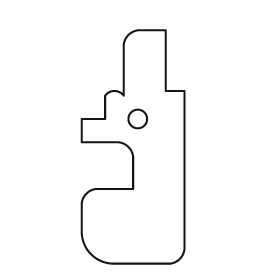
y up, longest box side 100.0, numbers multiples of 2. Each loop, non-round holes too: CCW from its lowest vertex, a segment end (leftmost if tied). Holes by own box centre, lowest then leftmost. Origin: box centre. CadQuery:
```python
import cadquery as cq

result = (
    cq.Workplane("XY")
    .moveTo(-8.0, -50.0)
    .lineTo(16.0, -50.0)
    .threePointArc((20.0, -48.0), (22.0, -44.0))
    .lineTo(22.0, 24.0)
    .lineTo(14.0, 24.0)
    .lineTo(14.0, 50.0)
    .lineTo(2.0, 50.0)
    .threePointArc((-2.0, 48.0), (-4.0, 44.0))
    .lineTo(-4.0, 22.0)
    .threePointArc((-8.0, 24.0), (-12.0, 22.0))
    .lineTo(-12.0, 12.0)
    .lineTo(-22.0, 12.0)
    .lineTo(-22.0, 2.0)
    .lineTo(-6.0, 2.0)
    .threePointArc((-2.0, 0.0), (0.0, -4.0))
    .lineTo(0.0, -18.0)
    .lineTo(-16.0, -18.0)
    .threePointArc((-20.0, -20.0), (-22.0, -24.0))
    .lineTo(-22.0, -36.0)
    .threePointArc((-18.0, -46.0), (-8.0, -50.0))
    .close()
    .moveTo(2.0, 12.0)
    .circle(4.0)
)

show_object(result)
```